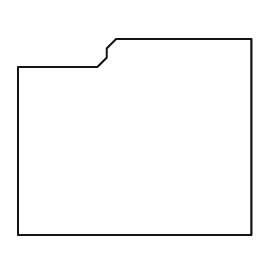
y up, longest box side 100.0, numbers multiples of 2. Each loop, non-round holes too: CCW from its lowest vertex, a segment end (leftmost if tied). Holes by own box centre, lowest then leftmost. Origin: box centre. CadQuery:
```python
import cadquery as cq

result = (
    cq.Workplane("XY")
    .moveTo(-50.0, -42.0)
    .lineTo(50.0, -42.0)
    .lineTo(50.0, 42.0)
    .lineTo(-8.0, 42.0)
    .lineTo(-12.0, 38.0)
    .lineTo(-12.0, 34.0)
    .lineTo(-16.0, 30.0)
    .lineTo(-50.0, 30.0)
    .close()
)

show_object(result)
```